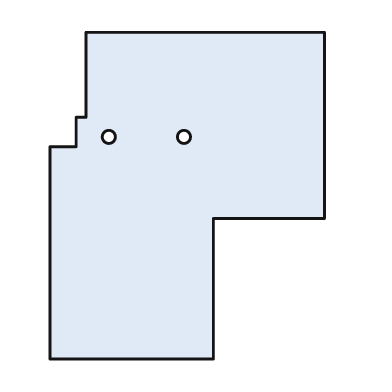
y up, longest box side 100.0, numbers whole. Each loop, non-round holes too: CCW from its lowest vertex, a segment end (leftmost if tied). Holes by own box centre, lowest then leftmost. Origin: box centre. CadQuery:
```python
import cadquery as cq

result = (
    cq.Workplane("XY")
    .moveTo(-42.0, -50.0)
    .lineTo(8.0, -50.0)
    .lineTo(8.0, -7.0)
    .lineTo(42.0, -7.0)
    .lineTo(42.0, 50.0)
    .lineTo(-31.0, 50.0)
    .lineTo(-31.0, 24.0)
    .lineTo(-34.0, 24.0)
    .lineTo(-34.0, 15.0)
    .lineTo(-42.0, 15.0)
    .close()
    .moveTo(-24.0, 18.0)
    .circle(2.0)
    .moveTo(-1.0, 18.0)
    .circle(2.0)
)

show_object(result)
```